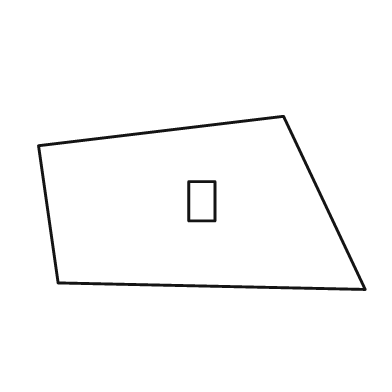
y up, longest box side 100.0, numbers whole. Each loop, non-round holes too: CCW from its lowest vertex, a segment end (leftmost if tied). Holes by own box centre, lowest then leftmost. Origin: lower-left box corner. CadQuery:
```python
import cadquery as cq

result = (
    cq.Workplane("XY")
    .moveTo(100.0, 0.0)
    .lineTo(75.0, 53.0)
    .lineTo(0.0, 44.0)
    .lineTo(6.0, 2.0)
    .close()
    .moveTo(46.0, 21.0)
    .lineTo(54.0, 21.0)
    .lineTo(54.0, 33.0)
    .lineTo(46.0, 33.0)
    .close()
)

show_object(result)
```